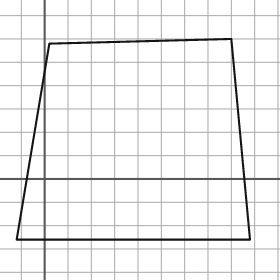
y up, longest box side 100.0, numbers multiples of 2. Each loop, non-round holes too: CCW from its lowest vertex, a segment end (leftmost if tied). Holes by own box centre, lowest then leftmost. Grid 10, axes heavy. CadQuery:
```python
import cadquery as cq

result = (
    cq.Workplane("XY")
    .moveTo(-12.0, -26.0)
    .lineTo(88.0, -26.0)
    .lineTo(80.0, 60.0)
    .lineTo(2.0, 58.0)
    .close()
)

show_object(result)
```